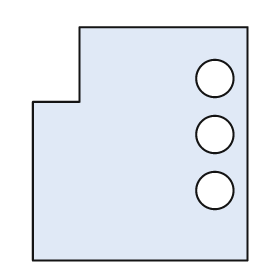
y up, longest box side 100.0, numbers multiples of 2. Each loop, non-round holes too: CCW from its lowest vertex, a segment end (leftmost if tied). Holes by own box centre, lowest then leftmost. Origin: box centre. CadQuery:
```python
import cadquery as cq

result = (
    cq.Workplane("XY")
    .moveTo(-46.0, -50.0)
    .lineTo(46.0, -50.0)
    .lineTo(46.0, 50.0)
    .lineTo(-26.0, 50.0)
    .lineTo(-26.0, 18.0)
    .lineTo(-46.0, 18.0)
    .close()
    .moveTo(32.0, -20.0)
    .circle(8.0)
    .moveTo(32.0, 4.0)
    .circle(8.0)
    .moveTo(32.0, 28.0)
    .circle(8.0)
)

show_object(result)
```